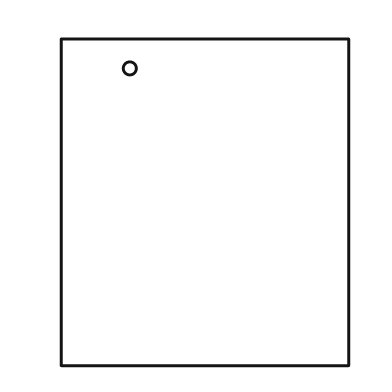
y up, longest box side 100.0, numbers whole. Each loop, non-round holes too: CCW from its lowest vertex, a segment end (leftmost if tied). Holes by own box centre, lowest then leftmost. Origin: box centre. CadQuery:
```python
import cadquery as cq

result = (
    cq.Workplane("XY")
    .moveTo(-44.0, -50.0)
    .lineTo(44.0, -50.0)
    .lineTo(44.0, 50.0)
    .lineTo(-44.0, 50.0)
    .close()
    .moveTo(-23.0, 41.0)
    .circle(2.0)
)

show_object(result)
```